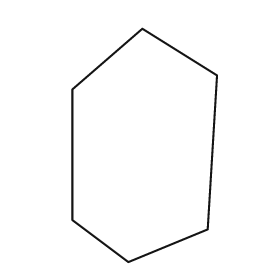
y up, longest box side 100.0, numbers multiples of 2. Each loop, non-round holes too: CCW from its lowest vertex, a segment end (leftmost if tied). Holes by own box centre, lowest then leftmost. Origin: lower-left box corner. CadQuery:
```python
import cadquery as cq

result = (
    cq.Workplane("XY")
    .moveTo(24.0, 0.0)
    .lineTo(58.0, 14.0)
    .lineTo(62.0, 80.0)
    .lineTo(30.0, 100.0)
    .lineTo(0.0, 74.0)
    .lineTo(0.0, 18.0)
    .close()
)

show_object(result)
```